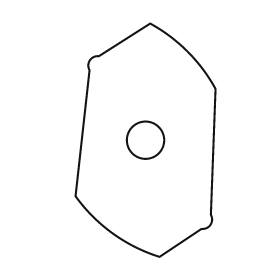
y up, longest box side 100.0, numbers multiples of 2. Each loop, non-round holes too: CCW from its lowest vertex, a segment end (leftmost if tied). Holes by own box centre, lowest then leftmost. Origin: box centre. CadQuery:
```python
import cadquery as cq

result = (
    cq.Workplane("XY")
    .moveTo(6.0, -50.0)
    .lineTo(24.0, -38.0)
    .threePointArc((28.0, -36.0), (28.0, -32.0))
    .lineTo(30.0, 22.0)
    .threePointArc((18.0, 38.0), (2.0, 50.0))
    .lineTo(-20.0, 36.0)
    .threePointArc((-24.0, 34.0), (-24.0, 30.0))
    .lineTo(-30.0, -24.0)
    .threePointArc((-14.0, -40.0), (6.0, -50.0))
    .close()
    .moveTo(0.0, 0.0)
    .circle(8.0)
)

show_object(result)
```